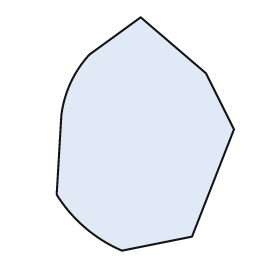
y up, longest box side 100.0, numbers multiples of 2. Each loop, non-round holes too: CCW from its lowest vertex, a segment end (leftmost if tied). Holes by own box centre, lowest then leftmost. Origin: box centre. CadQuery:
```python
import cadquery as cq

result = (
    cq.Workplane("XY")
    .moveTo(-10.0, -50.0)
    .lineTo(20.0, -44.0)
    .lineTo(38.0, 2.0)
    .lineTo(26.0, 26.0)
    .lineTo(-2.0, 50.0)
    .lineTo(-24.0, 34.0)
    .threePointArc((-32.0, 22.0), (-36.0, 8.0))
    .lineTo(-38.0, -26.0)
    .threePointArc((-26.0, -40.0), (-10.0, -50.0))
    .close()
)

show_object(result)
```